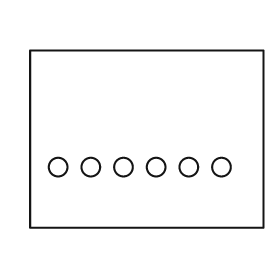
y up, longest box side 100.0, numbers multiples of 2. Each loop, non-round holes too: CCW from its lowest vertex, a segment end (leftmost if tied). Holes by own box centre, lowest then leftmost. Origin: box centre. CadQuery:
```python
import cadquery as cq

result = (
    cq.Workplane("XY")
    .moveTo(-50.0, -38.0)
    .lineTo(50.0, -38.0)
    .lineTo(50.0, 38.0)
    .lineTo(-50.0, 38.0)
    .close()
    .moveTo(-38.0, -12.0)
    .circle(4.0)
    .moveTo(-24.0, -12.0)
    .circle(4.0)
    .moveTo(-10.0, -12.0)
    .circle(4.0)
    .moveTo(4.0, -12.0)
    .circle(4.0)
    .moveTo(18.0, -12.0)
    .circle(4.0)
    .moveTo(32.0, -12.0)
    .circle(4.0)
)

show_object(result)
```